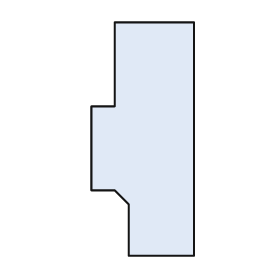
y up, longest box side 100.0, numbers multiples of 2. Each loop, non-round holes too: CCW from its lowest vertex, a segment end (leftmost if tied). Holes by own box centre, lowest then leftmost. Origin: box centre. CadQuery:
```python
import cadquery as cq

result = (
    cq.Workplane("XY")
    .moveTo(-6.0, -50.0)
    .lineTo(22.0, -50.0)
    .lineTo(22.0, 50.0)
    .lineTo(-12.0, 50.0)
    .lineTo(-12.0, 14.0)
    .lineTo(-22.0, 14.0)
    .lineTo(-22.0, -22.0)
    .lineTo(-12.0, -22.0)
    .lineTo(-6.0, -28.0)
    .close()
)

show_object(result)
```